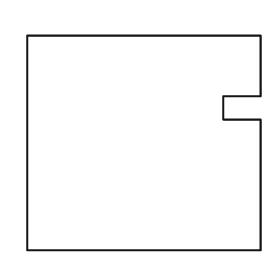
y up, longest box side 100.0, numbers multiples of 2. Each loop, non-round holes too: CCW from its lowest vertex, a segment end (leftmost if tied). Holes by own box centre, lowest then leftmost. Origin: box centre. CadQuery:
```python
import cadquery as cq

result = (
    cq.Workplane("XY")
    .moveTo(-50.0, -46.0)
    .lineTo(50.0, -46.0)
    .lineTo(50.0, 10.0)
    .lineTo(34.0, 10.0)
    .lineTo(34.0, 20.0)
    .lineTo(50.0, 20.0)
    .lineTo(50.0, 46.0)
    .lineTo(-50.0, 46.0)
    .close()
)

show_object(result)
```